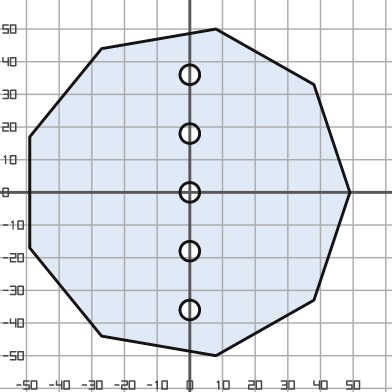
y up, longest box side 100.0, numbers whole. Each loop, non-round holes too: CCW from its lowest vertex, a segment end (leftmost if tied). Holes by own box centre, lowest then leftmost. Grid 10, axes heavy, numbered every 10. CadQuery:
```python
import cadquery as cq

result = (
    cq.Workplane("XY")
    .moveTo(8.0, -50.0)
    .lineTo(38.0, -33.0)
    .lineTo(49.0, 0.0)
    .lineTo(38.0, 33.0)
    .lineTo(8.0, 50.0)
    .lineTo(-27.0, 44.0)
    .lineTo(-49.0, 17.0)
    .lineTo(-49.0, -17.0)
    .lineTo(-27.0, -44.0)
    .close()
    .moveTo(0.0, -36.0)
    .circle(3.0)
    .moveTo(0.0, -18.0)
    .circle(3.0)
    .moveTo(0.0, 0.0)
    .circle(3.0)
    .moveTo(0.0, 18.0)
    .circle(3.0)
    .moveTo(0.0, 36.0)
    .circle(3.0)
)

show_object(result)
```